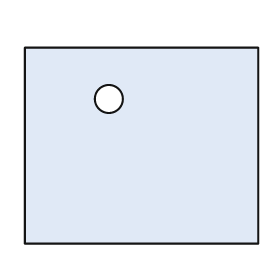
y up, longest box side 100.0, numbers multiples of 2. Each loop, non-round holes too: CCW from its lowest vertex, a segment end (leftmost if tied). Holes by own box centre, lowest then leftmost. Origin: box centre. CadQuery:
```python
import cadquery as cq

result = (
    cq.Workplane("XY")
    .moveTo(-50.0, -42.0)
    .lineTo(50.0, -42.0)
    .lineTo(50.0, 42.0)
    .lineTo(-50.0, 42.0)
    .close()
    .moveTo(-14.0, 20.0)
    .circle(6.0)
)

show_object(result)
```